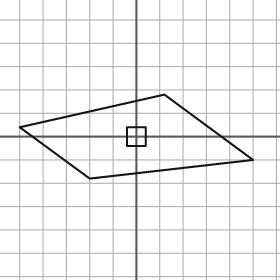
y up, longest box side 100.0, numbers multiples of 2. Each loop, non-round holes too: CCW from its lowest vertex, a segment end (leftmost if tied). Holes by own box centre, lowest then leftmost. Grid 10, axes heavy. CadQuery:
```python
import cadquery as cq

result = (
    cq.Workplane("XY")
    .moveTo(-20.0, -18.0)
    .lineTo(50.0, -10.0)
    .lineTo(12.0, 18.0)
    .lineTo(-50.0, 4.0)
    .close()
    .moveTo(-4.0, -4.0)
    .lineTo(4.0, -4.0)
    .lineTo(4.0, 4.0)
    .lineTo(-4.0, 4.0)
    .close()
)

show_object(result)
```